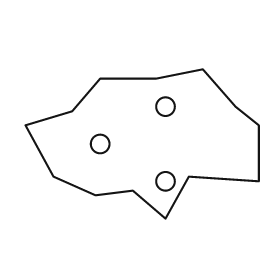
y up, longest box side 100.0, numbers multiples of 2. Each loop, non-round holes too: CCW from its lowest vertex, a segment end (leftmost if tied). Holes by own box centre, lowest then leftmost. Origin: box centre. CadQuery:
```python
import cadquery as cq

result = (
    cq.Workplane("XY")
    .moveTo(10.0, -32.0)
    .lineTo(20.0, -14.0)
    .lineTo(50.0, -16.0)
    .lineTo(50.0, 8.0)
    .lineTo(40.0, 16.0)
    .lineTo(26.0, 32.0)
    .lineTo(6.0, 28.0)
    .lineTo(-18.0, 28.0)
    .lineTo(-30.0, 14.0)
    .lineTo(-50.0, 8.0)
    .lineTo(-38.0, -14.0)
    .lineTo(-20.0, -22.0)
    .lineTo(-4.0, -20.0)
    .close()
    .moveTo(10.0, -16.0)
    .circle(4.0)
    .moveTo(-18.0, 0.0)
    .circle(4.0)
    .moveTo(10.0, 16.0)
    .circle(4.0)
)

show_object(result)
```